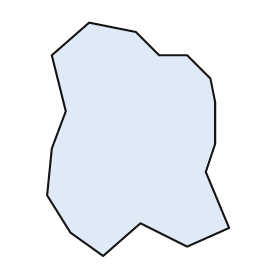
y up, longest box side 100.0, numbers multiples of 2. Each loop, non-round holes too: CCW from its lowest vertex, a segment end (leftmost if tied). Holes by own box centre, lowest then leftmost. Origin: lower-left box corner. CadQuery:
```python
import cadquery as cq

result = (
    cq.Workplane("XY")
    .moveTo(24.0, 0.0)
    .lineTo(40.0, 14.0)
    .lineTo(60.0, 4.0)
    .lineTo(78.0, 12.0)
    .lineTo(68.0, 36.0)
    .lineTo(72.0, 48.0)
    .lineTo(72.0, 66.0)
    .lineTo(70.0, 76.0)
    .lineTo(60.0, 86.0)
    .lineTo(48.0, 86.0)
    .lineTo(38.0, 96.0)
    .lineTo(18.0, 100.0)
    .lineTo(2.0, 86.0)
    .lineTo(8.0, 62.0)
    .lineTo(2.0, 46.0)
    .lineTo(0.0, 26.0)
    .lineTo(10.0, 10.0)
    .close()
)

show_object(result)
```